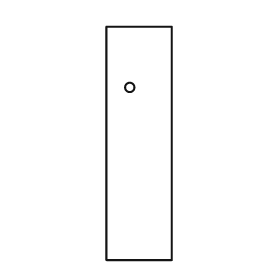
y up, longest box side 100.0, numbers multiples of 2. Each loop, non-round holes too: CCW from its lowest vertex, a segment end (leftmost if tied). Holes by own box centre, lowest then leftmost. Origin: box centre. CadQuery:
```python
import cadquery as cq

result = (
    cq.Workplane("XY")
    .moveTo(-14.0, -50.0)
    .lineTo(14.0, -50.0)
    .lineTo(14.0, 50.0)
    .lineTo(-14.0, 50.0)
    .close()
    .moveTo(-4.0, 24.0)
    .circle(2.0)
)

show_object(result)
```